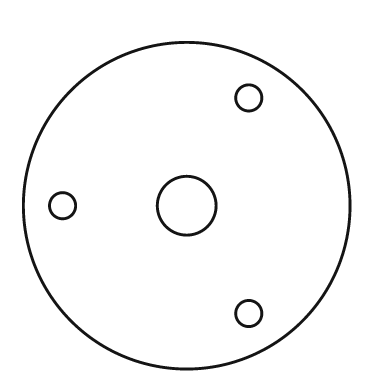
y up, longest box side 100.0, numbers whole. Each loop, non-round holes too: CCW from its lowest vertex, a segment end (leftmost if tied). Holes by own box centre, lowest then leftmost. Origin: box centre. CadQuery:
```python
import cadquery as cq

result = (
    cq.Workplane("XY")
    .moveTo(0.0, 0.0)
    .circle(50.0)
    .moveTo(19.0, -33.0)
    .circle(4.0)
    .moveTo(-38.0, 0.0)
    .circle(4.0)
    .moveTo(0.0, 0.0)
    .circle(9.0)
    .moveTo(19.0, 33.0)
    .circle(4.0)
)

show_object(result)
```